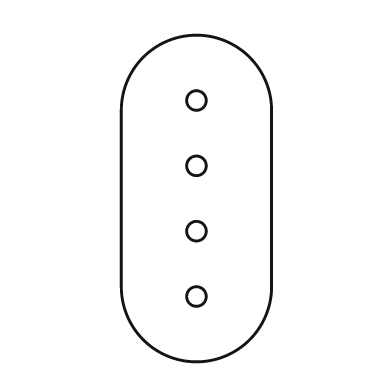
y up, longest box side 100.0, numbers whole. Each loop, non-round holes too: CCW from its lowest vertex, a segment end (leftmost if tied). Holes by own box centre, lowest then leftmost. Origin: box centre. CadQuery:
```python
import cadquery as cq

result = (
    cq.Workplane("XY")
    .moveTo(-23.0, -27.0)
    .threePointArc((0.0, -50.0), (23.0, -27.0))
    .lineTo(23.0, 27.0)
    .threePointArc((0.0, 50.0), (-23.0, 27.0))
    .close()
    .moveTo(0.0, -30.0)
    .circle(3.0)
    .moveTo(0.0, -10.0)
    .circle(3.0)
    .moveTo(0.0, 10.0)
    .circle(3.0)
    .moveTo(0.0, 30.0)
    .circle(3.0)
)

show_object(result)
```